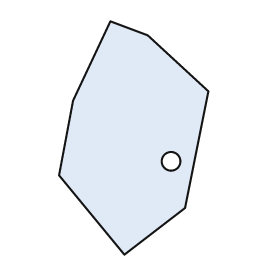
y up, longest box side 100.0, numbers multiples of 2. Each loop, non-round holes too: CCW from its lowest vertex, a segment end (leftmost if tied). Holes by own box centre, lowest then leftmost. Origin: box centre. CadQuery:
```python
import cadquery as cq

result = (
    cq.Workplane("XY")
    .moveTo(-4.0, -50.0)
    .lineTo(22.0, -30.0)
    .lineTo(32.0, 20.0)
    .lineTo(6.0, 44.0)
    .lineTo(-10.0, 50.0)
    .lineTo(-26.0, 16.0)
    .lineTo(-32.0, -16.0)
    .close()
    .moveTo(16.0, -10.0)
    .circle(4.0)
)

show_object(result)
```